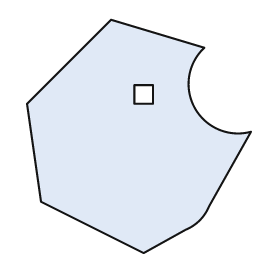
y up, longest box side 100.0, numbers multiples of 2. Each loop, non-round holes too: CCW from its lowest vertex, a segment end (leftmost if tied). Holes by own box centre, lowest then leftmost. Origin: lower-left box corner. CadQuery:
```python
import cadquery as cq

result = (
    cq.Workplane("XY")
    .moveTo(50.0, 0.0)
    .lineTo(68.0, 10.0)
    .threePointArc((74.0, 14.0), (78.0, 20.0))
    .lineTo(96.0, 52.0)
    .threePointArc((72.0, 62.0), (76.0, 88.0))
    .lineTo(36.0, 100.0)
    .lineTo(0.0, 64.0)
    .lineTo(6.0, 22.0)
    .close()
    .moveTo(46.0, 64.0)
    .lineTo(54.0, 64.0)
    .lineTo(54.0, 72.0)
    .lineTo(46.0, 72.0)
    .close()
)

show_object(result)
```